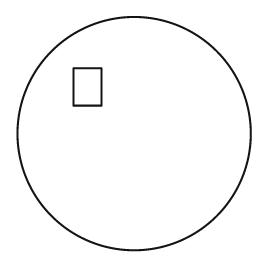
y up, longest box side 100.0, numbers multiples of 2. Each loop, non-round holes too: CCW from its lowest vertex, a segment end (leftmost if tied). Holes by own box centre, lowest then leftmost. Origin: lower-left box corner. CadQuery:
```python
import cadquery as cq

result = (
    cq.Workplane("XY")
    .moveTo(50.0, 50.0)
    .circle(50.0)
    .moveTo(24.0, 62.0)
    .lineTo(36.0, 62.0)
    .lineTo(36.0, 78.0)
    .lineTo(24.0, 78.0)
    .close()
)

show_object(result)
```